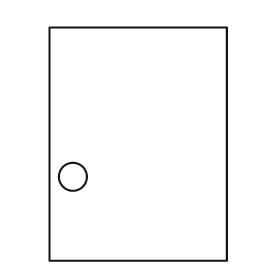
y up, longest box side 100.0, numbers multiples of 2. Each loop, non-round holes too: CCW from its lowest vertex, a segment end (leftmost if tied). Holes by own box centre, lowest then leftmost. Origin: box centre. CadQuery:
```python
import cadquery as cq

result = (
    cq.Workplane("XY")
    .moveTo(-38.0, -50.0)
    .lineTo(38.0, -50.0)
    .lineTo(38.0, 50.0)
    .lineTo(-38.0, 50.0)
    .close()
    .moveTo(-28.0, -14.0)
    .circle(6.0)
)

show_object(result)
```